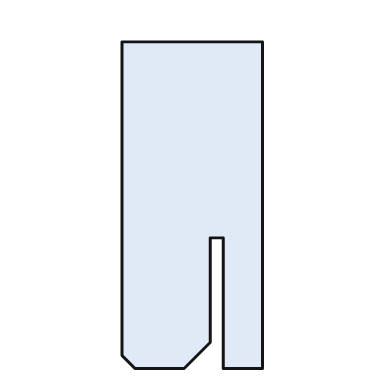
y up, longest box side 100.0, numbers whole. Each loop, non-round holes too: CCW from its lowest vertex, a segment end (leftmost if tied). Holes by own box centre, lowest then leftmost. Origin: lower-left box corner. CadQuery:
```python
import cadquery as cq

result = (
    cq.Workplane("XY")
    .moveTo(4.0, 0.0)
    .lineTo(19.0, 0.0)
    .lineTo(27.0, 8.0)
    .lineTo(27.0, 40.0)
    .lineTo(31.0, 40.0)
    .lineTo(31.0, 0.0)
    .lineTo(43.0, 0.0)
    .lineTo(43.0, 100.0)
    .lineTo(0.0, 100.0)
    .lineTo(0.0, 4.0)
    .close()
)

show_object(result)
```